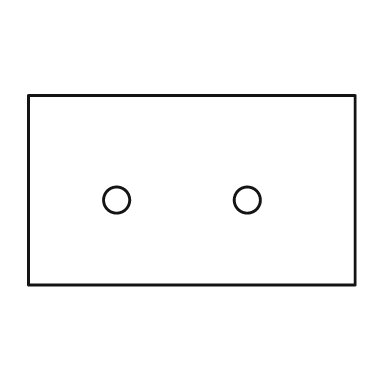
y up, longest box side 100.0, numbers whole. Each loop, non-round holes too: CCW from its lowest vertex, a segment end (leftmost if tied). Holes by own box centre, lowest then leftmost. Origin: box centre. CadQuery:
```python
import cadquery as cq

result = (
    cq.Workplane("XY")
    .moveTo(-50.0, -29.0)
    .lineTo(50.0, -29.0)
    .lineTo(50.0, 29.0)
    .lineTo(-50.0, 29.0)
    .close()
    .moveTo(-23.0, -3.0)
    .circle(4.0)
    .moveTo(17.0, -3.0)
    .circle(4.0)
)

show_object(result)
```